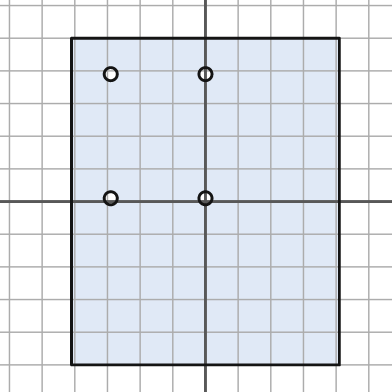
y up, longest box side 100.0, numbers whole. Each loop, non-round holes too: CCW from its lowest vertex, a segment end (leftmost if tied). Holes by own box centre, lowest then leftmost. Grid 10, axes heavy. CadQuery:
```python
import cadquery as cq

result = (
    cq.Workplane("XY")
    .moveTo(-41.0, -50.0)
    .lineTo(41.0, -50.0)
    .lineTo(41.0, 50.0)
    .lineTo(-41.0, 50.0)
    .close()
    .moveTo(-29.0, 1.0)
    .circle(2.0)
    .moveTo(0.0, 1.0)
    .circle(2.0)
    .moveTo(-29.0, 39.0)
    .circle(2.0)
    .moveTo(0.0, 39.0)
    .circle(2.0)
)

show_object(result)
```